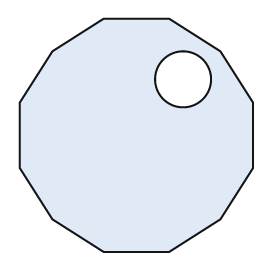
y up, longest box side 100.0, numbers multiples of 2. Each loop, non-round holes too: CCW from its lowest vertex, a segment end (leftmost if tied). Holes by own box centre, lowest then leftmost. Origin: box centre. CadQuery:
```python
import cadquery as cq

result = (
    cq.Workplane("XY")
    .moveTo(-14.0, -50.0)
    .lineTo(14.0, -50.0)
    .lineTo(36.0, -36.0)
    .lineTo(50.0, -14.0)
    .lineTo(50.0, 14.0)
    .lineTo(36.0, 36.0)
    .lineTo(14.0, 50.0)
    .lineTo(-14.0, 50.0)
    .lineTo(-36.0, 36.0)
    .lineTo(-50.0, 14.0)
    .lineTo(-50.0, -14.0)
    .lineTo(-36.0, -36.0)
    .close()
    .moveTo(20.0, 24.0)
    .circle(12.0)
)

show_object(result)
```